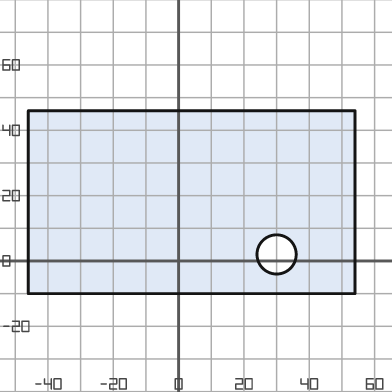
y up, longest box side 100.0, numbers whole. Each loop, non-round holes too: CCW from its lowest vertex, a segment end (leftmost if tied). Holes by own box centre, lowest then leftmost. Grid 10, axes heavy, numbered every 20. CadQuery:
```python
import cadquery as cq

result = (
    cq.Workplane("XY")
    .moveTo(-46.0, -10.0)
    .lineTo(54.0, -10.0)
    .lineTo(54.0, 46.0)
    .lineTo(-46.0, 46.0)
    .close()
    .moveTo(30.0, 2.0)
    .circle(6.0)
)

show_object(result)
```